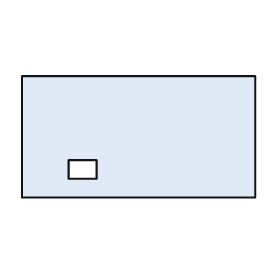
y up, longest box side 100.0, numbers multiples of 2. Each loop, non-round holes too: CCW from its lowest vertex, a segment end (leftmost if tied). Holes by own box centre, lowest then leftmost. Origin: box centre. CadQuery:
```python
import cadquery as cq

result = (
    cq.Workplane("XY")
    .moveTo(-50.0, -26.0)
    .lineTo(50.0, -26.0)
    .lineTo(50.0, 26.0)
    .lineTo(-50.0, 26.0)
    .close()
    .moveTo(-30.0, -18.0)
    .lineTo(-18.0, -18.0)
    .lineTo(-18.0, -10.0)
    .lineTo(-30.0, -10.0)
    .close()
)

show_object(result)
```